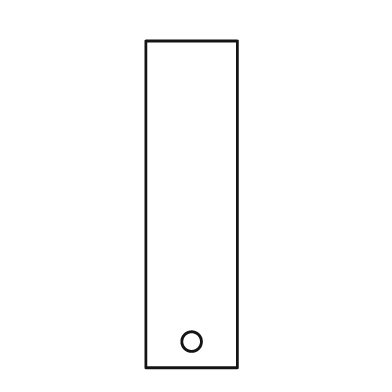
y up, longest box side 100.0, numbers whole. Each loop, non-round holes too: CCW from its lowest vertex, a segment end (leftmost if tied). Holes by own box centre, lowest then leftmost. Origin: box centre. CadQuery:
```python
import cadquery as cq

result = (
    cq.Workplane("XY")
    .moveTo(-14.0, -50.0)
    .lineTo(14.0, -50.0)
    .lineTo(14.0, 50.0)
    .lineTo(-14.0, 50.0)
    .close()
    .moveTo(0.0, -42.0)
    .circle(3.0)
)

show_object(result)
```